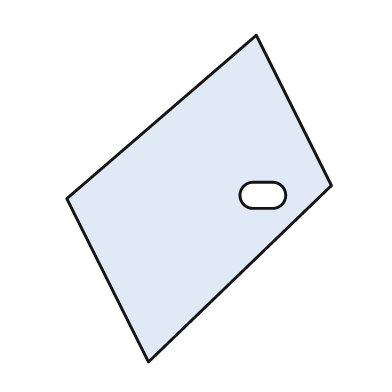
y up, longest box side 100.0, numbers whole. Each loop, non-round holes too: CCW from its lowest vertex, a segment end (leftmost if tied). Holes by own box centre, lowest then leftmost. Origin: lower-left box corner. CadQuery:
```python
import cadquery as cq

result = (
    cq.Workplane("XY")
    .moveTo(25.0, 0.0)
    .lineTo(81.0, 54.0)
    .lineTo(58.0, 100.0)
    .lineTo(0.0, 50.0)
    .close()
    .moveTo(57.0, 47.0)
    .lineTo(63.0, 47.0)
    .threePointArc((67.0, 51.0), (63.0, 55.0))
    .lineTo(57.0, 55.0)
    .threePointArc((53.0, 51.0), (57.0, 47.0))
    .close()
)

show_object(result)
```